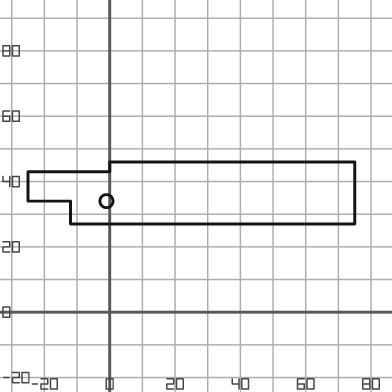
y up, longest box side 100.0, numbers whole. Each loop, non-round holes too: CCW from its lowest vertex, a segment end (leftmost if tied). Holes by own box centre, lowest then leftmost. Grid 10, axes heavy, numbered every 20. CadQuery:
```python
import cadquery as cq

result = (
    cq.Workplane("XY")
    .moveTo(-12.0, 27.0)
    .lineTo(75.0, 27.0)
    .lineTo(75.0, 46.0)
    .lineTo(0.0, 46.0)
    .lineTo(0.0, 43.0)
    .lineTo(-25.0, 43.0)
    .lineTo(-25.0, 34.0)
    .lineTo(-12.0, 34.0)
    .close()
    .moveTo(-1.0, 34.0)
    .circle(2.0)
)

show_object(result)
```